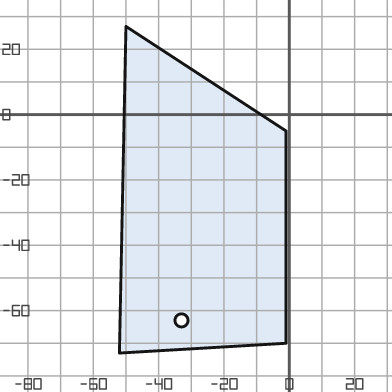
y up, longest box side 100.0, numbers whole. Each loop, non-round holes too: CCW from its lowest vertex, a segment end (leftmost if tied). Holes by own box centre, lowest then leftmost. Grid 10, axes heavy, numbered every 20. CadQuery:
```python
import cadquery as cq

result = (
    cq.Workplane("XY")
    .moveTo(-52.0, -73.0)
    .lineTo(-1.0, -70.0)
    .lineTo(-1.0, -5.0)
    .lineTo(-50.0, 27.0)
    .close()
    .moveTo(-33.0, -63.0)
    .circle(2.0)
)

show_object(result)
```